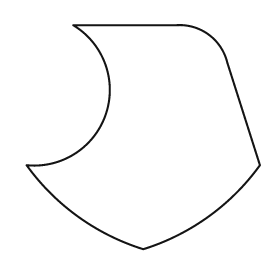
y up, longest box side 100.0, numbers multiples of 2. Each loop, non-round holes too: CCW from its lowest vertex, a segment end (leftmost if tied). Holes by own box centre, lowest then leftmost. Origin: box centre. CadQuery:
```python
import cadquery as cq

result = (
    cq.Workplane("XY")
    .moveTo(0.0, -48.0)
    .threePointArc((28.0, -34.0), (50.0, -12.0))
    .lineTo(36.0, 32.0)
    .threePointArc((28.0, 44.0), (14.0, 48.0))
    .lineTo(-30.0, 48.0)
    .threePointArc((-16.0, 10.0), (-50.0, -12.0))
    .threePointArc((-28.0, -34.0), (0.0, -48.0))
    .close()
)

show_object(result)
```